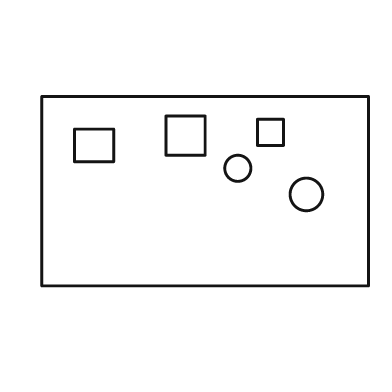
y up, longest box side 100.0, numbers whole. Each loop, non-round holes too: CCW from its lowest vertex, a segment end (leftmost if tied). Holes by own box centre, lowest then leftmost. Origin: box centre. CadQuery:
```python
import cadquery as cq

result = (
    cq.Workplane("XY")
    .moveTo(-50.0, -29.0)
    .lineTo(50.0, -29.0)
    .lineTo(50.0, 29.0)
    .lineTo(-50.0, 29.0)
    .close()
    .moveTo(31.0, -1.0)
    .circle(5.0)
    .moveTo(10.0, 7.0)
    .circle(4.0)
    .moveTo(-40.0, 9.0)
    .lineTo(-28.0, 9.0)
    .lineTo(-28.0, 19.0)
    .lineTo(-40.0, 19.0)
    .close()
    .moveTo(-12.0, 11.0)
    .lineTo(0.0, 11.0)
    .lineTo(0.0, 23.0)
    .lineTo(-12.0, 23.0)
    .close()
    .moveTo(16.0, 14.0)
    .lineTo(24.0, 14.0)
    .lineTo(24.0, 22.0)
    .lineTo(16.0, 22.0)
    .close()
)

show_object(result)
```